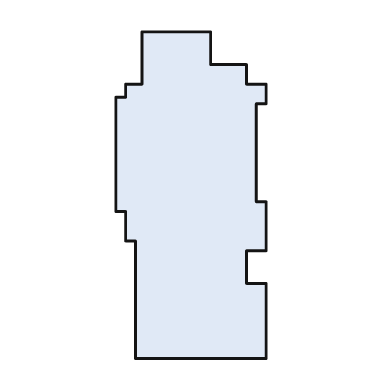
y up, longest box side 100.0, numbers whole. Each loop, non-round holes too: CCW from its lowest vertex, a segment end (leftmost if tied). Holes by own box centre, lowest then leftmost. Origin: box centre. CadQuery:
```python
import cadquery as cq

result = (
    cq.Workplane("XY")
    .moveTo(-17.0, -50.0)
    .lineTo(23.0, -50.0)
    .lineTo(23.0, -27.0)
    .lineTo(17.0, -27.0)
    .lineTo(17.0, -17.0)
    .lineTo(23.0, -17.0)
    .lineTo(23.0, -2.0)
    .lineTo(20.0, -2.0)
    .lineTo(20.0, 28.0)
    .lineTo(23.0, 28.0)
    .lineTo(23.0, 34.0)
    .lineTo(17.0, 34.0)
    .lineTo(17.0, 40.0)
    .lineTo(6.0, 40.0)
    .lineTo(6.0, 50.0)
    .lineTo(-15.0, 50.0)
    .lineTo(-15.0, 34.0)
    .lineTo(-20.0, 34.0)
    .lineTo(-20.0, 30.0)
    .lineTo(-23.0, 30.0)
    .lineTo(-23.0, -5.0)
    .lineTo(-20.0, -5.0)
    .lineTo(-20.0, -14.0)
    .lineTo(-17.0, -14.0)
    .close()
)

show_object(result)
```